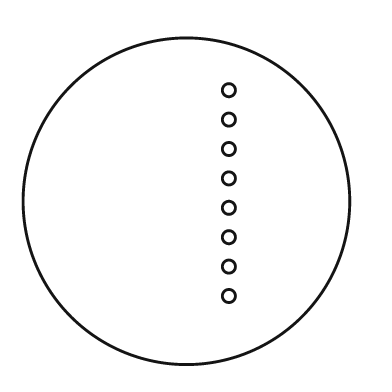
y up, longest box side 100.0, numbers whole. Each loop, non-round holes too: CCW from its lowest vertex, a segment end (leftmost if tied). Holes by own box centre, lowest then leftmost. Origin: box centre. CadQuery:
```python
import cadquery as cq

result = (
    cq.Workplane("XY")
    .moveTo(0.0, 0.0)
    .circle(50.0)
    .moveTo(13.0, -29.0)
    .circle(2.0)
    .moveTo(13.0, -20.0)
    .circle(2.0)
    .moveTo(13.0, -11.0)
    .circle(2.0)
    .moveTo(13.0, -2.0)
    .circle(2.0)
    .moveTo(13.0, 7.0)
    .circle(2.0)
    .moveTo(13.0, 16.0)
    .circle(2.0)
    .moveTo(13.0, 25.0)
    .circle(2.0)
    .moveTo(13.0, 34.0)
    .circle(2.0)
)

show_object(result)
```